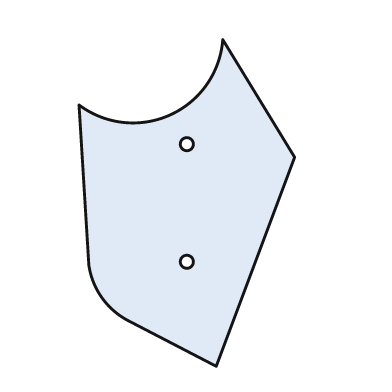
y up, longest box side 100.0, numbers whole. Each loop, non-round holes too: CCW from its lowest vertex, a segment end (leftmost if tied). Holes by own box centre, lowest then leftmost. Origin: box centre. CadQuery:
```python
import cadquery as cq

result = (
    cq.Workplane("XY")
    .moveTo(9.0, -50.0)
    .lineTo(33.0, 14.0)
    .lineTo(11.0, 50.0)
    .threePointArc((-5.0, 27.0), (-33.0, 30.0))
    .lineTo(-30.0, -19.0)
    .threePointArc((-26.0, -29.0), (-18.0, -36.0))
    .close()
    .moveTo(0.0, -18.0)
    .circle(2.0)
    .moveTo(0.0, 18.0)
    .circle(2.0)
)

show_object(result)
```